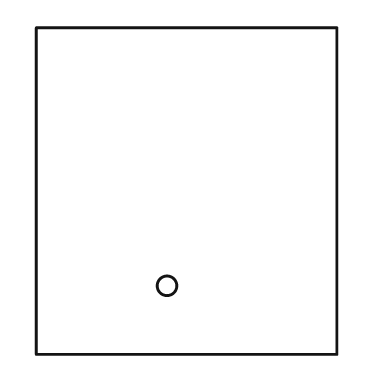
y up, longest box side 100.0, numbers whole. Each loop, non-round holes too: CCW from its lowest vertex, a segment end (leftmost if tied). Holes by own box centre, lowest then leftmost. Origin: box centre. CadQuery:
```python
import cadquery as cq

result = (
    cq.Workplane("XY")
    .moveTo(-46.0, -50.0)
    .lineTo(46.0, -50.0)
    .lineTo(46.0, 50.0)
    .lineTo(-46.0, 50.0)
    .close()
    .moveTo(-6.0, -29.0)
    .circle(3.0)
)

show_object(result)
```